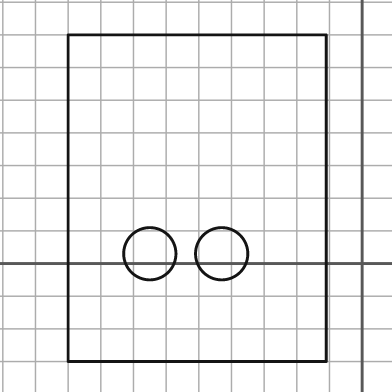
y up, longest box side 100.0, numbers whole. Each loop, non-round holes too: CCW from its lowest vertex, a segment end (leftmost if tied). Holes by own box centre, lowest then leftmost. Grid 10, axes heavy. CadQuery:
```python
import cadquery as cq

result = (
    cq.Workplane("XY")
    .moveTo(-90.0, -30.0)
    .lineTo(-11.0, -30.0)
    .lineTo(-11.0, 70.0)
    .lineTo(-90.0, 70.0)
    .close()
    .moveTo(-65.0, 3.0)
    .circle(8.0)
    .moveTo(-43.0, 3.0)
    .circle(8.0)
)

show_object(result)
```